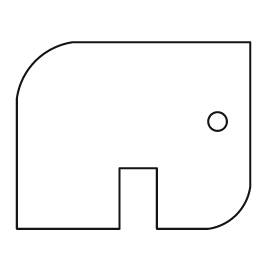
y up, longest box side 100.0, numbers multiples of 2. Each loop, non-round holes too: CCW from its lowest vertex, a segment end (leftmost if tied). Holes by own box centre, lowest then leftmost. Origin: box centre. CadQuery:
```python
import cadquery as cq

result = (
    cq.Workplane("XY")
    .moveTo(-50.0, -40.0)
    .lineTo(-6.0, -40.0)
    .lineTo(-6.0, -14.0)
    .lineTo(10.0, -14.0)
    .lineTo(10.0, -40.0)
    .lineTo(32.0, -40.0)
    .threePointArc((44.0, -34.0), (50.0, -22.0))
    .lineTo(50.0, 40.0)
    .lineTo(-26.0, 40.0)
    .threePointArc((-42.0, 32.0), (-50.0, 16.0))
    .close()
    .moveTo(36.0, 6.0)
    .circle(4.0)
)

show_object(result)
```